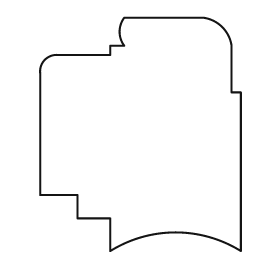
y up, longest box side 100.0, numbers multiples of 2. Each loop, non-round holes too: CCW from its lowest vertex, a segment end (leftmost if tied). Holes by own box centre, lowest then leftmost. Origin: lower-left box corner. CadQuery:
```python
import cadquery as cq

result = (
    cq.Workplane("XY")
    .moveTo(30.0, 0.0)
    .threePointArc((58.0, 8.0), (86.0, 0.0))
    .lineTo(86.0, 68.0)
    .lineTo(82.0, 68.0)
    .lineTo(82.0, 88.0)
    .threePointArc((78.0, 96.0), (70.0, 100.0))
    .lineTo(36.0, 100.0)
    .threePointArc((34.0, 94.0), (36.0, 88.0))
    .lineTo(30.0, 88.0)
    .lineTo(30.0, 84.0)
    .lineTo(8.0, 84.0)
    .threePointArc((2.0, 82.0), (0.0, 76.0))
    .lineTo(0.0, 24.0)
    .lineTo(16.0, 24.0)
    .lineTo(16.0, 14.0)
    .lineTo(30.0, 14.0)
    .close()
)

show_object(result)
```